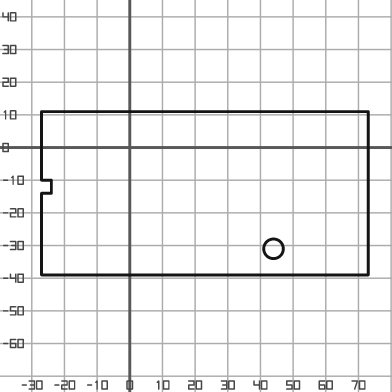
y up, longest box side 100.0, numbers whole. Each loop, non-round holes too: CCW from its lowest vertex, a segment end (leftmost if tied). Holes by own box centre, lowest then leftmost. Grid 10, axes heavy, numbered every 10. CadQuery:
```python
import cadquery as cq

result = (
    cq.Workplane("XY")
    .moveTo(-27.0, -39.0)
    .lineTo(73.0, -39.0)
    .lineTo(73.0, 11.0)
    .lineTo(-27.0, 11.0)
    .lineTo(-27.0, -10.0)
    .lineTo(-24.0, -10.0)
    .lineTo(-24.0, -14.0)
    .lineTo(-27.0, -14.0)
    .close()
    .moveTo(44.0, -31.0)
    .circle(3.0)
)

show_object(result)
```